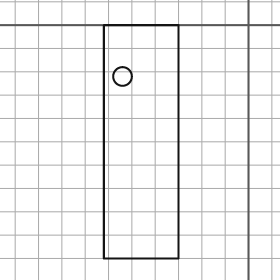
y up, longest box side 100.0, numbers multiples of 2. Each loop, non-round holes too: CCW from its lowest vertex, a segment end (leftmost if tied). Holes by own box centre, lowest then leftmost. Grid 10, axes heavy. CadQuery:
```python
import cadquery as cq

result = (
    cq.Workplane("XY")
    .moveTo(-62.0, -100.0)
    .lineTo(-30.0, -100.0)
    .lineTo(-30.0, 0.0)
    .lineTo(-62.0, 0.0)
    .close()
    .moveTo(-54.0, -22.0)
    .circle(4.0)
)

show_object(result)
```